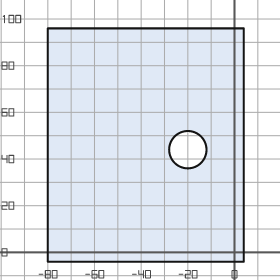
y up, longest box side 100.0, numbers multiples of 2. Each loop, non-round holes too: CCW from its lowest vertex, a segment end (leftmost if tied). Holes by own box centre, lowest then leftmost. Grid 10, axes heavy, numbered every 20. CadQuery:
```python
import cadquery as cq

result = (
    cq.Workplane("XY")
    .moveTo(-80.0, -4.0)
    .lineTo(4.0, -4.0)
    .lineTo(4.0, 96.0)
    .lineTo(-80.0, 96.0)
    .close()
    .moveTo(-20.0, 44.0)
    .circle(8.0)
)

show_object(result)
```